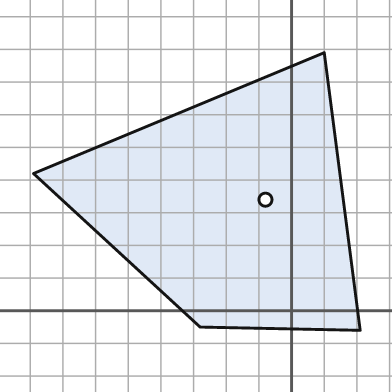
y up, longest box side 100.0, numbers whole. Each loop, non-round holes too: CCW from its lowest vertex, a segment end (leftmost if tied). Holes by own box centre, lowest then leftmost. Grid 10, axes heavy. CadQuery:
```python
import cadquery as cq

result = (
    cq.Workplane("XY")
    .moveTo(21.0, -6.0)
    .lineTo(10.0, 79.0)
    .lineTo(-79.0, 42.0)
    .lineTo(-28.0, -5.0)
    .close()
    .moveTo(-8.0, 34.0)
    .circle(2.0)
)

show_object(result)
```